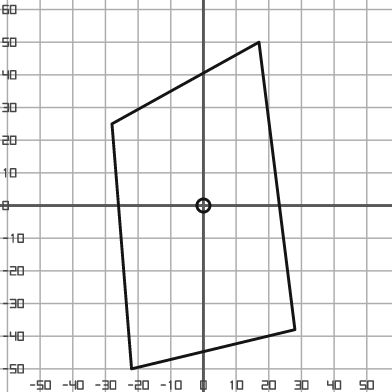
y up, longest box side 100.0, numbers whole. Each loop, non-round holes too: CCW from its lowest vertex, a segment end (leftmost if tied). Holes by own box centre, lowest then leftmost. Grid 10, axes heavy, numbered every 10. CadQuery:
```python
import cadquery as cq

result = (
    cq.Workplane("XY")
    .moveTo(-22.0, -50.0)
    .lineTo(28.0, -38.0)
    .lineTo(17.0, 50.0)
    .lineTo(-28.0, 25.0)
    .close()
    .moveTo(0.0, 0.0)
    .circle(2.0)
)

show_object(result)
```